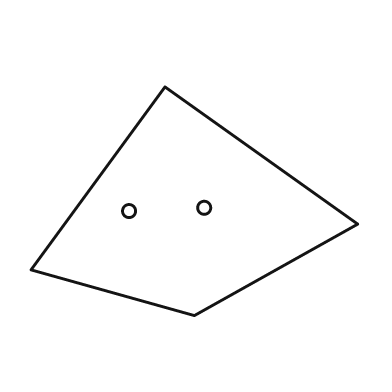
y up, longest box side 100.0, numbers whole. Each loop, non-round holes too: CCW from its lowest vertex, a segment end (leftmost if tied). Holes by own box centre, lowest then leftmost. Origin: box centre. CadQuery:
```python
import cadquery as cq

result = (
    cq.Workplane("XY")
    .moveTo(0.0, -35.0)
    .lineTo(50.0, -7.0)
    .lineTo(-9.0, 35.0)
    .lineTo(-50.0, -21.0)
    .close()
    .moveTo(-20.0, -3.0)
    .circle(2.0)
    .moveTo(3.0, -2.0)
    .circle(2.0)
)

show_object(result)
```